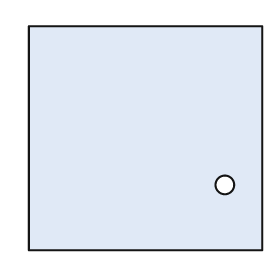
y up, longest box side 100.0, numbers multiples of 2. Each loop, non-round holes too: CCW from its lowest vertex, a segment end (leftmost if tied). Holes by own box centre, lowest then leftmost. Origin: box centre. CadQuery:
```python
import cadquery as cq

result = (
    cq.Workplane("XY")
    .moveTo(-50.0, -48.0)
    .lineTo(50.0, -48.0)
    .lineTo(50.0, 48.0)
    .lineTo(-50.0, 48.0)
    .close()
    .moveTo(34.0, -20.0)
    .circle(4.0)
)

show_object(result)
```